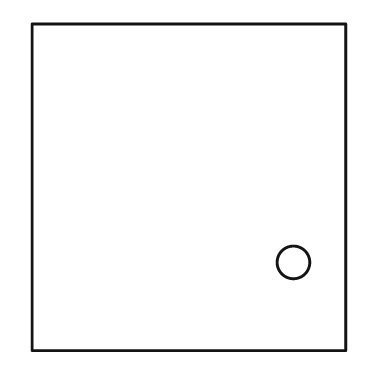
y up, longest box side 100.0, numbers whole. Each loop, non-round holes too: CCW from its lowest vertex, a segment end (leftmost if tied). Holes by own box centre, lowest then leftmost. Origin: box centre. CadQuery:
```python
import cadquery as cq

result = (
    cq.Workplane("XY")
    .moveTo(-48.0, -50.0)
    .lineTo(48.0, -50.0)
    .lineTo(48.0, 50.0)
    .lineTo(-48.0, 50.0)
    .close()
    .moveTo(32.0, -23.0)
    .circle(5.0)
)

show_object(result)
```